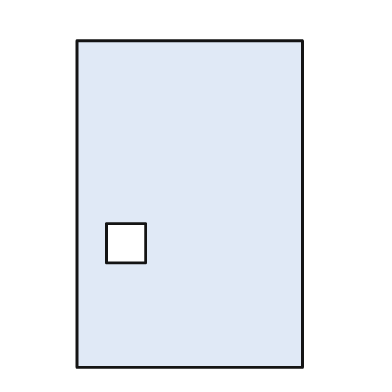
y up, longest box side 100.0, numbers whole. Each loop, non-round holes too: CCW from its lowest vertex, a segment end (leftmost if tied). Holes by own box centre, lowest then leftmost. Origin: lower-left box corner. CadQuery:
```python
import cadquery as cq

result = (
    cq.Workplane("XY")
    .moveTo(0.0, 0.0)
    .lineTo(69.0, 0.0)
    .lineTo(69.0, 100.0)
    .lineTo(0.0, 100.0)
    .close()
    .moveTo(9.0, 32.0)
    .lineTo(21.0, 32.0)
    .lineTo(21.0, 44.0)
    .lineTo(9.0, 44.0)
    .close()
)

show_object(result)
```